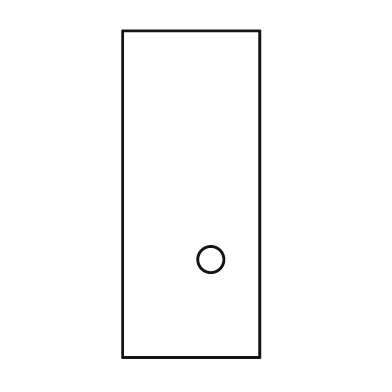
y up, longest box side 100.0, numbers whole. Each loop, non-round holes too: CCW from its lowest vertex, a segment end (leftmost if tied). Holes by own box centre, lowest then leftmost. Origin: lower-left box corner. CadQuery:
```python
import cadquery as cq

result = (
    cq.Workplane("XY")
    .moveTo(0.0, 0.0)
    .lineTo(42.0, 0.0)
    .lineTo(42.0, 100.0)
    .lineTo(0.0, 100.0)
    .close()
    .moveTo(27.0, 30.0)
    .circle(4.0)
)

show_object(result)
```